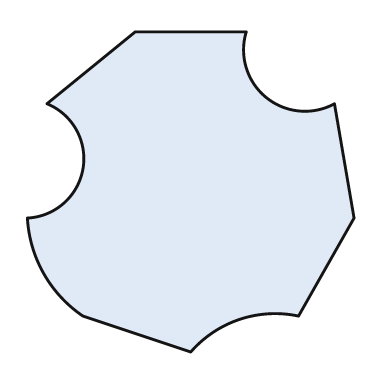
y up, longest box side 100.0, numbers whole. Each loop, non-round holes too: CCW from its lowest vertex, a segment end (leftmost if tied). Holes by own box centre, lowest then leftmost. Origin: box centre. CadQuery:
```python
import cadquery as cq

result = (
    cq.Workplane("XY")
    .moveTo(0.0, -49.0)
    .threePointArc((15.0, -39.0), (33.0, -38.0))
    .lineTo(50.0, -8.0)
    .lineTo(44.0, 27.0)
    .threePointArc((23.0, 29.0), (17.0, 49.0))
    .lineTo(-17.0, 49.0)
    .lineTo(-44.0, 27.0)
    .threePointArc((-33.0, 7.0), (-50.0, -8.0))
    .threePointArc((-45.0, -25.0), (-33.0, -38.0))
    .close()
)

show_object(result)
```